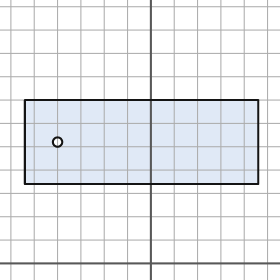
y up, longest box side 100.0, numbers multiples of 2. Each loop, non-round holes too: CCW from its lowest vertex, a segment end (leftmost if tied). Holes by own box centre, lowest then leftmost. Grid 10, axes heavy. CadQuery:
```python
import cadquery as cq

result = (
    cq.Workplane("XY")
    .moveTo(-54.0, 34.0)
    .lineTo(46.0, 34.0)
    .lineTo(46.0, 70.0)
    .lineTo(-54.0, 70.0)
    .close()
    .moveTo(-40.0, 52.0)
    .circle(2.0)
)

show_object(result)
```